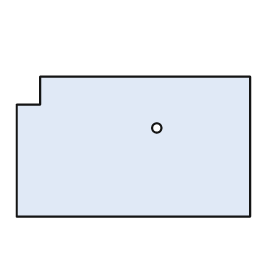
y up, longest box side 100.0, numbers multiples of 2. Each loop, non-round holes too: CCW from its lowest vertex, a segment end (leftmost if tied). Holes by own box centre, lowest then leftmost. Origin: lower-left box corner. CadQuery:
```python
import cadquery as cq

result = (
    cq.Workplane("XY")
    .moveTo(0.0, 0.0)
    .lineTo(100.0, 0.0)
    .lineTo(100.0, 60.0)
    .lineTo(10.0, 60.0)
    .lineTo(10.0, 48.0)
    .lineTo(0.0, 48.0)
    .close()
    .moveTo(60.0, 38.0)
    .circle(2.0)
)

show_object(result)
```